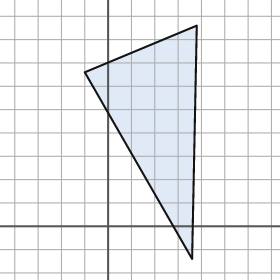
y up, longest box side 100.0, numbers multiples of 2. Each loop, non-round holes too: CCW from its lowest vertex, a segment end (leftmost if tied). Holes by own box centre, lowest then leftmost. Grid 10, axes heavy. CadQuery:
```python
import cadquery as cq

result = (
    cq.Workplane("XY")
    .moveTo(36.0, -14.0)
    .lineTo(38.0, 86.0)
    .lineTo(-10.0, 66.0)
    .close()
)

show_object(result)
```